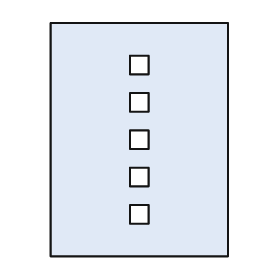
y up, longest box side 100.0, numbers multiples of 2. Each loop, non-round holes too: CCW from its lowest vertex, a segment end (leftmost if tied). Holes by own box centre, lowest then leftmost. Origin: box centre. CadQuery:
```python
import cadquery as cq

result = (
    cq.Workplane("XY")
    .moveTo(-38.0, -50.0)
    .lineTo(38.0, -50.0)
    .lineTo(38.0, 50.0)
    .lineTo(-38.0, 50.0)
    .close()
    .moveTo(-4.0, -36.0)
    .lineTo(4.0, -36.0)
    .lineTo(4.0, -28.0)
    .lineTo(-4.0, -28.0)
    .close()
    .moveTo(-4.0, -20.0)
    .lineTo(4.0, -20.0)
    .lineTo(4.0, -12.0)
    .lineTo(-4.0, -12.0)
    .close()
    .moveTo(-4.0, -4.0)
    .lineTo(4.0, -4.0)
    .lineTo(4.0, 4.0)
    .lineTo(-4.0, 4.0)
    .close()
    .moveTo(-4.0, 12.0)
    .lineTo(4.0, 12.0)
    .lineTo(4.0, 20.0)
    .lineTo(-4.0, 20.0)
    .close()
    .moveTo(-4.0, 28.0)
    .lineTo(4.0, 28.0)
    .lineTo(4.0, 36.0)
    .lineTo(-4.0, 36.0)
    .close()
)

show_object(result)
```